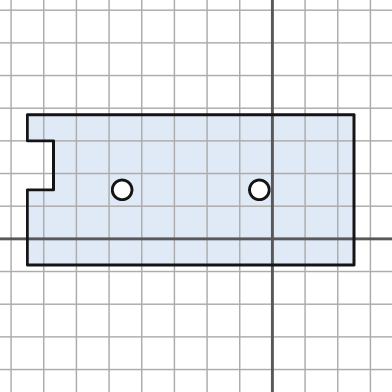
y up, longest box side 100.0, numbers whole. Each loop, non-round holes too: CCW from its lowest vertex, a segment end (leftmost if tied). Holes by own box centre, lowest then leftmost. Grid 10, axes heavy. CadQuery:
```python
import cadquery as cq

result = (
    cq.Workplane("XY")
    .moveTo(-75.0, -8.0)
    .lineTo(25.0, -8.0)
    .lineTo(25.0, 38.0)
    .lineTo(-75.0, 38.0)
    .lineTo(-75.0, 30.0)
    .lineTo(-67.0, 30.0)
    .lineTo(-67.0, 15.0)
    .lineTo(-75.0, 15.0)
    .close()
    .moveTo(-46.0, 15.0)
    .circle(3.0)
    .moveTo(-4.0, 15.0)
    .circle(3.0)
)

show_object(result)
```